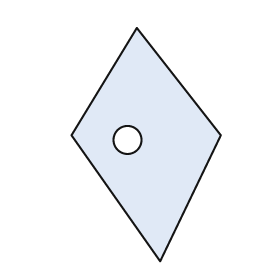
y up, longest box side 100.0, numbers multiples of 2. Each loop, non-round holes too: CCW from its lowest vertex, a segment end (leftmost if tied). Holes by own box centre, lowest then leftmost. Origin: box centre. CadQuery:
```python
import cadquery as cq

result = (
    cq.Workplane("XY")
    .moveTo(6.0, -50.0)
    .lineTo(32.0, 4.0)
    .lineTo(-4.0, 50.0)
    .lineTo(-32.0, 4.0)
    .close()
    .moveTo(-8.0, 2.0)
    .circle(6.0)
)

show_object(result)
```